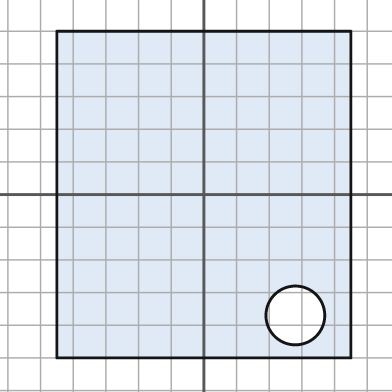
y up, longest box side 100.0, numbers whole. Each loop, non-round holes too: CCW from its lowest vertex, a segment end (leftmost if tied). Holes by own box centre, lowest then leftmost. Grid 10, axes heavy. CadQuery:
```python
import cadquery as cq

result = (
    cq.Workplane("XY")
    .moveTo(-45.0, -50.0)
    .lineTo(45.0, -50.0)
    .lineTo(45.0, 50.0)
    .lineTo(-45.0, 50.0)
    .close()
    .moveTo(28.0, -37.0)
    .circle(9.0)
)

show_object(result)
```